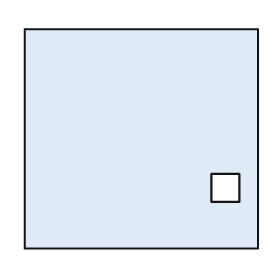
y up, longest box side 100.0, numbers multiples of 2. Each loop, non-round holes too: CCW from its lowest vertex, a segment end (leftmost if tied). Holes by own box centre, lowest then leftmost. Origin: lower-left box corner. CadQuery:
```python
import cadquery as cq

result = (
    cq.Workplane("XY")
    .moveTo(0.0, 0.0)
    .lineTo(100.0, 0.0)
    .lineTo(100.0, 94.0)
    .lineTo(0.0, 94.0)
    .close()
    .moveTo(80.0, 20.0)
    .lineTo(92.0, 20.0)
    .lineTo(92.0, 32.0)
    .lineTo(80.0, 32.0)
    .close()
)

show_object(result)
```